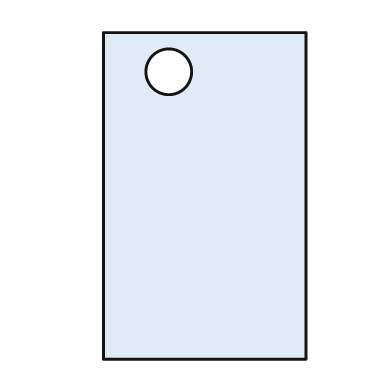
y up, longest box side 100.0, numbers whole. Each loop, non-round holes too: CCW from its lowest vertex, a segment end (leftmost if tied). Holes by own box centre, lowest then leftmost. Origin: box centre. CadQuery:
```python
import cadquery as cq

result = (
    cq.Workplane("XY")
    .moveTo(-31.0, -50.0)
    .lineTo(31.0, -50.0)
    .lineTo(31.0, 50.0)
    .lineTo(-31.0, 50.0)
    .close()
    .moveTo(-11.0, 38.0)
    .circle(7.0)
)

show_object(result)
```